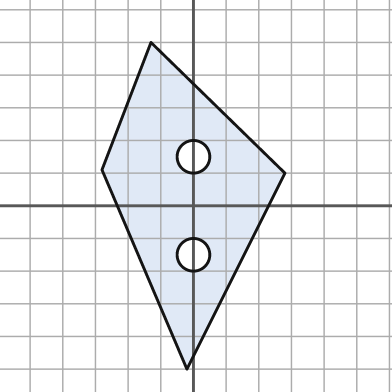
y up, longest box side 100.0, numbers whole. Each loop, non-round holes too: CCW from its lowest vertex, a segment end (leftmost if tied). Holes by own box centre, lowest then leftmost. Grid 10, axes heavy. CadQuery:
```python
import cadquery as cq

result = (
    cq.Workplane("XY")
    .moveTo(-2.0, -50.0)
    .lineTo(28.0, 10.0)
    .lineTo(-13.0, 50.0)
    .lineTo(-28.0, 11.0)
    .close()
    .moveTo(0.0, -15.0)
    .circle(5.0)
    .moveTo(0.0, 15.0)
    .circle(5.0)
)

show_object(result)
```